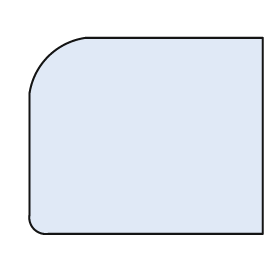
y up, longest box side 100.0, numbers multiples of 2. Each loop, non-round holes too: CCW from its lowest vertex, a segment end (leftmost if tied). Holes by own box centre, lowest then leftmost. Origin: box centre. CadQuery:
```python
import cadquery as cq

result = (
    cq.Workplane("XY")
    .moveTo(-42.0, -42.0)
    .lineTo(50.0, -42.0)
    .lineTo(50.0, 42.0)
    .lineTo(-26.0, 42.0)
    .threePointArc((-42.0, 34.0), (-50.0, 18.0))
    .lineTo(-50.0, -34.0)
    .threePointArc((-48.0, -40.0), (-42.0, -42.0))
    .close()
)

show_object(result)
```